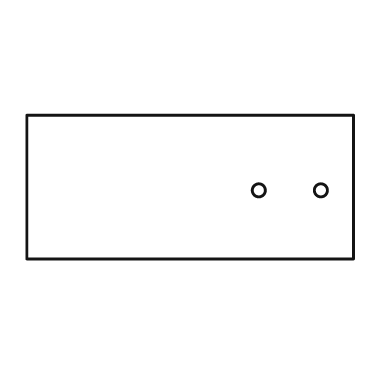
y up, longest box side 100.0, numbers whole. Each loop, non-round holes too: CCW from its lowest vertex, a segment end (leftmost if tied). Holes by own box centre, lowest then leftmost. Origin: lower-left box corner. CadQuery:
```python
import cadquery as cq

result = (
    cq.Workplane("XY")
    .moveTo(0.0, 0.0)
    .lineTo(100.0, 0.0)
    .lineTo(100.0, 44.0)
    .lineTo(0.0, 44.0)
    .close()
    .moveTo(71.0, 21.0)
    .circle(2.0)
    .moveTo(90.0, 21.0)
    .circle(2.0)
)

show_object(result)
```